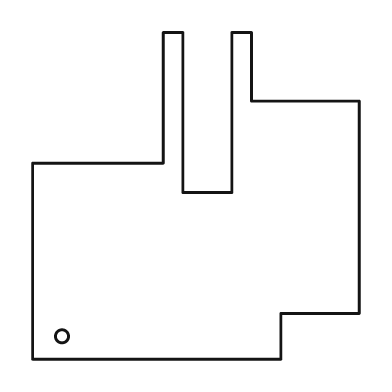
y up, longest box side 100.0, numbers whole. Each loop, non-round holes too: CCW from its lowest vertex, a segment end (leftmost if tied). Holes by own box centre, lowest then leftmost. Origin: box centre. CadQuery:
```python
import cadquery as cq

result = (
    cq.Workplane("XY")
    .moveTo(-50.0, -50.0)
    .lineTo(26.0, -50.0)
    .lineTo(26.0, -36.0)
    .lineTo(50.0, -36.0)
    .lineTo(50.0, 29.0)
    .lineTo(17.0, 29.0)
    .lineTo(17.0, 50.0)
    .lineTo(11.0, 50.0)
    .lineTo(11.0, 1.0)
    .lineTo(-4.0, 1.0)
    .lineTo(-4.0, 50.0)
    .lineTo(-10.0, 50.0)
    .lineTo(-10.0, 10.0)
    .lineTo(-50.0, 10.0)
    .close()
    .moveTo(-41.0, -43.0)
    .circle(2.0)
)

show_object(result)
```